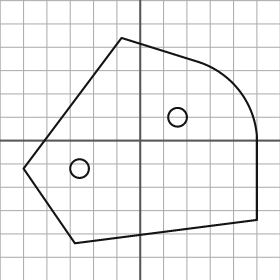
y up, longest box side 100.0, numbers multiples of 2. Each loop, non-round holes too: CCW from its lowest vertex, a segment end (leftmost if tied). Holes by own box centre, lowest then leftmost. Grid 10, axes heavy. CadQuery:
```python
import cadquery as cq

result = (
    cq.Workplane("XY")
    .moveTo(-28.0, -44.0)
    .lineTo(50.0, -34.0)
    .lineTo(50.0, 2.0)
    .threePointArc((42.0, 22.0), (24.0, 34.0))
    .lineTo(-8.0, 44.0)
    .lineTo(-50.0, -12.0)
    .close()
    .moveTo(-26.0, -12.0)
    .circle(4.0)
    .moveTo(16.0, 10.0)
    .circle(4.0)
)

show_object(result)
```